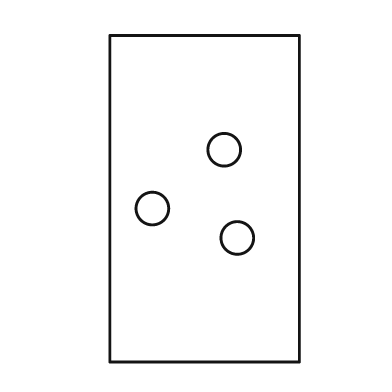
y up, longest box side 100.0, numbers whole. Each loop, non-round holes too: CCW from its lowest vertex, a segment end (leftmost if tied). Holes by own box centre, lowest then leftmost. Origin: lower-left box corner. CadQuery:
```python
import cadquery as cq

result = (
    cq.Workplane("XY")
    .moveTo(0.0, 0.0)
    .lineTo(58.0, 0.0)
    .lineTo(58.0, 100.0)
    .lineTo(0.0, 100.0)
    .close()
    .moveTo(39.0, 38.0)
    .circle(5.0)
    .moveTo(13.0, 47.0)
    .circle(5.0)
    .moveTo(35.0, 65.0)
    .circle(5.0)
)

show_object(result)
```